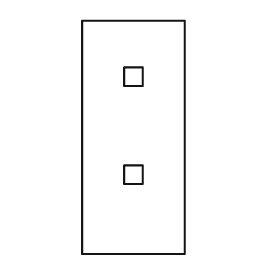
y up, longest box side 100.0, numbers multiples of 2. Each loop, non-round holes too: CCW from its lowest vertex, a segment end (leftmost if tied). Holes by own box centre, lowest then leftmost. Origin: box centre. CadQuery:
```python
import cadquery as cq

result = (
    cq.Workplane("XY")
    .moveTo(-22.0, -50.0)
    .lineTo(22.0, -50.0)
    .lineTo(22.0, 50.0)
    .lineTo(-22.0, 50.0)
    .close()
    .moveTo(-4.0, -20.0)
    .lineTo(4.0, -20.0)
    .lineTo(4.0, -12.0)
    .lineTo(-4.0, -12.0)
    .close()
    .moveTo(-4.0, 22.0)
    .lineTo(4.0, 22.0)
    .lineTo(4.0, 30.0)
    .lineTo(-4.0, 30.0)
    .close()
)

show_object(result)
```